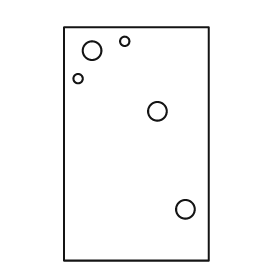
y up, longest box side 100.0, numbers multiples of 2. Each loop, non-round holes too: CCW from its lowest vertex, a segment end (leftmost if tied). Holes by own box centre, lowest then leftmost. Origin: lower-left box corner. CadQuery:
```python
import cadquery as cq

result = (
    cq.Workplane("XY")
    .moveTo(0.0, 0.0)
    .lineTo(62.0, 0.0)
    .lineTo(62.0, 100.0)
    .lineTo(0.0, 100.0)
    .close()
    .moveTo(52.0, 22.0)
    .circle(4.0)
    .moveTo(40.0, 64.0)
    .circle(4.0)
    .moveTo(6.0, 78.0)
    .circle(2.0)
    .moveTo(12.0, 90.0)
    .circle(4.0)
    .moveTo(26.0, 94.0)
    .circle(2.0)
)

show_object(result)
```